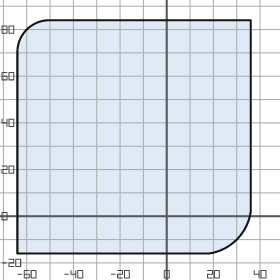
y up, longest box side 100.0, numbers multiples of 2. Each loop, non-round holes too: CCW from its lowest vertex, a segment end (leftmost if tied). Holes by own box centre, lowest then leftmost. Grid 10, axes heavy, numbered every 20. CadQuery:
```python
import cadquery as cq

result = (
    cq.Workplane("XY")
    .moveTo(-64.0, -16.0)
    .lineTo(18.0, -16.0)
    .threePointArc((30.0, -10.0), (36.0, 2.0))
    .lineTo(36.0, 84.0)
    .lineTo(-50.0, 84.0)
    .threePointArc((-60.0, 80.0), (-64.0, 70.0))
    .close()
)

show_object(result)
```